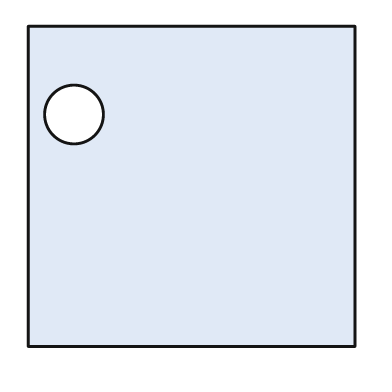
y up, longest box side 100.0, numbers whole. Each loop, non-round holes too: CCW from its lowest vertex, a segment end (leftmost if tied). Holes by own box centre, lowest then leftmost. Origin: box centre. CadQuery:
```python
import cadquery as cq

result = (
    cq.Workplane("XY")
    .moveTo(-50.0, -49.0)
    .lineTo(50.0, -49.0)
    .lineTo(50.0, 49.0)
    .lineTo(-50.0, 49.0)
    .close()
    .moveTo(-36.0, 22.0)
    .circle(9.0)
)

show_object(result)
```